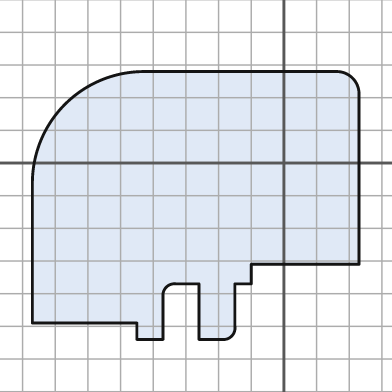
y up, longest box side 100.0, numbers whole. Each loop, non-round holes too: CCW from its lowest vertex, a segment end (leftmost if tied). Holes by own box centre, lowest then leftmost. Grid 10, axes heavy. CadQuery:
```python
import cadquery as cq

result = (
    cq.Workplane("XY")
    .moveTo(-45.0, -54.0)
    .lineTo(-37.0, -54.0)
    .lineTo(-37.0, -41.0)
    .threePointArc((-36.0, -38.0), (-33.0, -37.0))
    .lineTo(-26.0, -37.0)
    .lineTo(-26.0, -54.0)
    .lineTo(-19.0, -54.0)
    .threePointArc((-16.0, -53.0), (-15.0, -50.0))
    .lineTo(-15.0, -37.0)
    .lineTo(-10.0, -37.0)
    .lineTo(-10.0, -31.0)
    .lineTo(23.0, -31.0)
    .lineTo(23.0, 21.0)
    .threePointArc((21.0, 26.0), (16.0, 28.0))
    .lineTo(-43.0, 28.0)
    .threePointArc((-67.0, 18.0), (-77.0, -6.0))
    .lineTo(-77.0, -49.0)
    .lineTo(-45.0, -49.0)
    .close()
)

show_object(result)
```